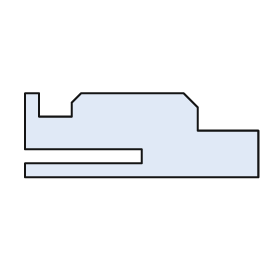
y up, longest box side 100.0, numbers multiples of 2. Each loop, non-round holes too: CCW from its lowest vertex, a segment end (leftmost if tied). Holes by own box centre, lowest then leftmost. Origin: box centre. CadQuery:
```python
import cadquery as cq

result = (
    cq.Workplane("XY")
    .moveTo(-50.0, -18.0)
    .lineTo(50.0, -18.0)
    .lineTo(50.0, 2.0)
    .lineTo(24.0, 2.0)
    .lineTo(24.0, 12.0)
    .lineTo(18.0, 18.0)
    .lineTo(-26.0, 18.0)
    .lineTo(-30.0, 14.0)
    .lineTo(-30.0, 8.0)
    .lineTo(-44.0, 8.0)
    .lineTo(-44.0, 18.0)
    .lineTo(-50.0, 18.0)
    .lineTo(-50.0, -6.0)
    .lineTo(0.0, -6.0)
    .lineTo(0.0, -12.0)
    .lineTo(-50.0, -12.0)
    .close()
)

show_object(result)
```